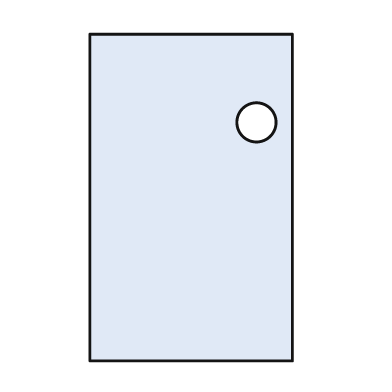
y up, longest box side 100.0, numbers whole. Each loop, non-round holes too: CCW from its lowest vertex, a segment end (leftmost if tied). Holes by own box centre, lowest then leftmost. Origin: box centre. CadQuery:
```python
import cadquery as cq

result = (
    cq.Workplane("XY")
    .moveTo(-31.0, -50.0)
    .lineTo(31.0, -50.0)
    .lineTo(31.0, 50.0)
    .lineTo(-31.0, 50.0)
    .close()
    .moveTo(20.0, 23.0)
    .circle(6.0)
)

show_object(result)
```